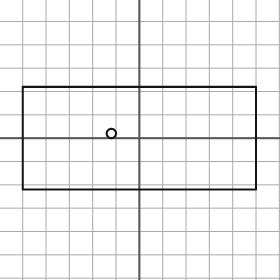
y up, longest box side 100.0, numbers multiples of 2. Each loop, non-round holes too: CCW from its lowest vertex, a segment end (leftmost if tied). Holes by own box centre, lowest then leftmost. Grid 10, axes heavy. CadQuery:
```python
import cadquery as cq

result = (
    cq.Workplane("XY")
    .moveTo(-50.0, -22.0)
    .lineTo(50.0, -22.0)
    .lineTo(50.0, 22.0)
    .lineTo(-50.0, 22.0)
    .close()
    .moveTo(-12.0, 2.0)
    .circle(2.0)
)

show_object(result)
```